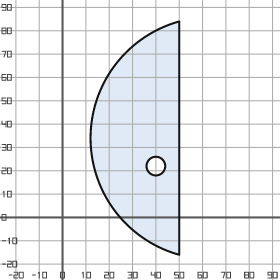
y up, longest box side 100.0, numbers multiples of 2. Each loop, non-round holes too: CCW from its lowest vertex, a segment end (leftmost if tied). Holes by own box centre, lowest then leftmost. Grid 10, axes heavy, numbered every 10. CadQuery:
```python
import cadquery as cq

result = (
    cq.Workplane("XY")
    .moveTo(50.0, -16.0)
    .lineTo(50.0, 84.0)
    .threePointArc((12.0, 34.0), (50.0, -16.0))
    .close()
    .moveTo(40.0, 22.0)
    .circle(4.0)
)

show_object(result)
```